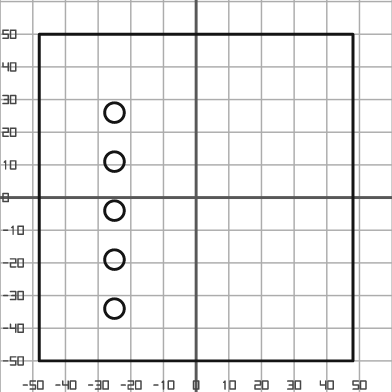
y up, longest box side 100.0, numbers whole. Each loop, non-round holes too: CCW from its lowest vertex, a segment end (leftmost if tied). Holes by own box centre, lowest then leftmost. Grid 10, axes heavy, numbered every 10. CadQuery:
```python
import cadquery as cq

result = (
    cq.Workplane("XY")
    .moveTo(-48.0, -50.0)
    .lineTo(48.0, -50.0)
    .lineTo(48.0, 50.0)
    .lineTo(-48.0, 50.0)
    .close()
    .moveTo(-25.0, -34.0)
    .circle(3.0)
    .moveTo(-25.0, -19.0)
    .circle(3.0)
    .moveTo(-25.0, -4.0)
    .circle(3.0)
    .moveTo(-25.0, 11.0)
    .circle(3.0)
    .moveTo(-25.0, 26.0)
    .circle(3.0)
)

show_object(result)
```